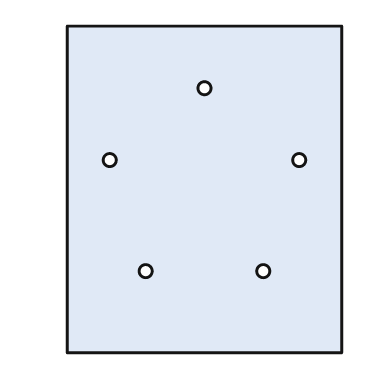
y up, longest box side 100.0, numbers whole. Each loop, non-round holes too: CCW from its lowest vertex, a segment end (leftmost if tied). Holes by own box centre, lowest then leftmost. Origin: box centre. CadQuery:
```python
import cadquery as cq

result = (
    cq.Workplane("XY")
    .moveTo(-42.0, -50.0)
    .lineTo(42.0, -50.0)
    .lineTo(42.0, 50.0)
    .lineTo(-42.0, 50.0)
    .close()
    .moveTo(-18.0, -25.0)
    .circle(2.0)
    .moveTo(18.0, -25.0)
    .circle(2.0)
    .moveTo(-29.0, 9.0)
    .circle(2.0)
    .moveTo(29.0, 9.0)
    .circle(2.0)
    .moveTo(0.0, 31.0)
    .circle(2.0)
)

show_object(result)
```